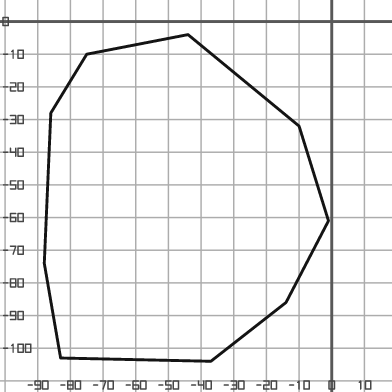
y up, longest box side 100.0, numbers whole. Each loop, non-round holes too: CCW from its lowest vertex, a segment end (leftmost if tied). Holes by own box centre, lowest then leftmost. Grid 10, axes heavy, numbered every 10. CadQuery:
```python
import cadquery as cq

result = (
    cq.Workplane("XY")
    .moveTo(-37.0, -104.0)
    .lineTo(-14.0, -86.0)
    .lineTo(-1.0, -61.0)
    .lineTo(-10.0, -32.0)
    .lineTo(-44.0, -4.0)
    .lineTo(-75.0, -10.0)
    .lineTo(-86.0, -28.0)
    .lineTo(-88.0, -74.0)
    .lineTo(-83.0, -103.0)
    .close()
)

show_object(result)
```